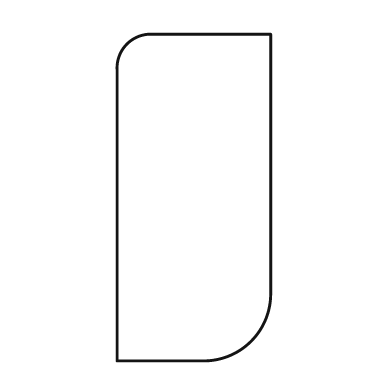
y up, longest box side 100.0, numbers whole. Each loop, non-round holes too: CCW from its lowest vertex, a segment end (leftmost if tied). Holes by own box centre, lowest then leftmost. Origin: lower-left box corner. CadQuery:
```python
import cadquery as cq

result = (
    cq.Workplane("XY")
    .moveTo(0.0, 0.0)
    .lineTo(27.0, 0.0)
    .threePointArc((41.0, 6.0), (47.0, 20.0))
    .lineTo(47.0, 100.0)
    .lineTo(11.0, 100.0)
    .threePointArc((3.0, 97.0), (0.0, 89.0))
    .close()
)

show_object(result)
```